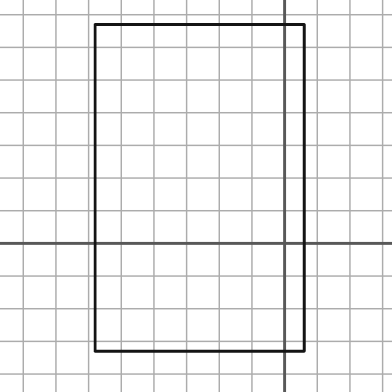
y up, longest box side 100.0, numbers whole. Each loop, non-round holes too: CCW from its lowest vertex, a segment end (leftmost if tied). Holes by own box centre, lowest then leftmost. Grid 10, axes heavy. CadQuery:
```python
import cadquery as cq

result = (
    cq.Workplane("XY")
    .moveTo(-58.0, -33.0)
    .lineTo(6.0, -33.0)
    .lineTo(6.0, 67.0)
    .lineTo(-58.0, 67.0)
    .close()
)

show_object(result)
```